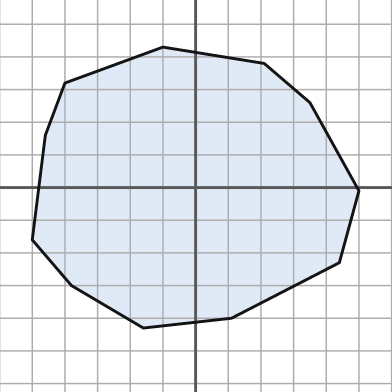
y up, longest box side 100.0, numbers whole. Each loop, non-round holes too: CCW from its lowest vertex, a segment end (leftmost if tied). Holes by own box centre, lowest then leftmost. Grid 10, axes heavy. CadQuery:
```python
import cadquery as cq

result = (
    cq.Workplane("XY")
    .moveTo(-16.0, -43.0)
    .lineTo(11.0, -40.0)
    .lineTo(44.0, -23.0)
    .lineTo(50.0, -1.0)
    .lineTo(35.0, 26.0)
    .lineTo(21.0, 38.0)
    .lineTo(-10.0, 43.0)
    .lineTo(-40.0, 32.0)
    .lineTo(-46.0, 16.0)
    .lineTo(-50.0, -16.0)
    .lineTo(-38.0, -30.0)
    .close()
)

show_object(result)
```